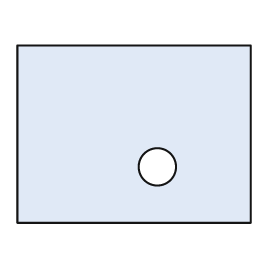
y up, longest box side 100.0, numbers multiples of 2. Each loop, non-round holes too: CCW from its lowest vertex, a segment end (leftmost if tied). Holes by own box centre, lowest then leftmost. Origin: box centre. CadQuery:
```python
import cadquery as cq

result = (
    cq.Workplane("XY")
    .moveTo(-50.0, -38.0)
    .lineTo(50.0, -38.0)
    .lineTo(50.0, 38.0)
    .lineTo(-50.0, 38.0)
    .close()
    .moveTo(10.0, -14.0)
    .circle(8.0)
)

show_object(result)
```